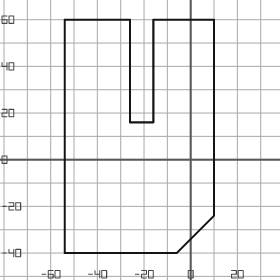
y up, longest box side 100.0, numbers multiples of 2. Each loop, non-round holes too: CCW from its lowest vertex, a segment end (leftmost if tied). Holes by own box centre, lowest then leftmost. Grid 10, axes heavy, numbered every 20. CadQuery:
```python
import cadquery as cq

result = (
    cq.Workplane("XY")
    .moveTo(-54.0, -40.0)
    .lineTo(-6.0, -40.0)
    .lineTo(10.0, -24.0)
    .lineTo(10.0, 60.0)
    .lineTo(-16.0, 60.0)
    .lineTo(-16.0, 16.0)
    .lineTo(-26.0, 16.0)
    .lineTo(-26.0, 60.0)
    .lineTo(-54.0, 60.0)
    .close()
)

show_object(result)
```